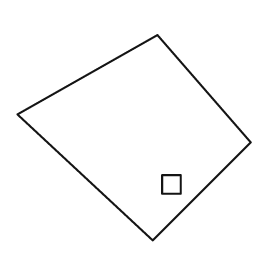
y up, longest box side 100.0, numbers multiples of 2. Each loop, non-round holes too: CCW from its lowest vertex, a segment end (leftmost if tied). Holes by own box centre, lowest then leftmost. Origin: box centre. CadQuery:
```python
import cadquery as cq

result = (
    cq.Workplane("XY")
    .moveTo(8.0, -44.0)
    .lineTo(50.0, -2.0)
    .lineTo(10.0, 44.0)
    .lineTo(-50.0, 10.0)
    .close()
    .moveTo(12.0, -24.0)
    .lineTo(20.0, -24.0)
    .lineTo(20.0, -16.0)
    .lineTo(12.0, -16.0)
    .close()
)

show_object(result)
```